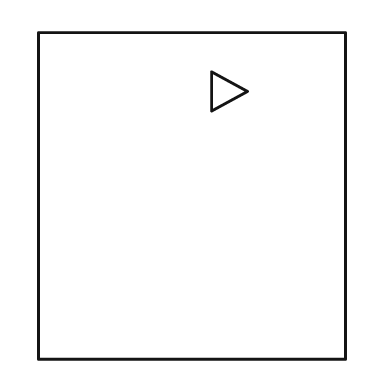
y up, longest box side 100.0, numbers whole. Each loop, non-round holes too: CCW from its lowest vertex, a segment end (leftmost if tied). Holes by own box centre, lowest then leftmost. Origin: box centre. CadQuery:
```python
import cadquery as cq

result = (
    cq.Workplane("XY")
    .moveTo(-47.0, -50.0)
    .lineTo(47.0, -50.0)
    .lineTo(47.0, 50.0)
    .lineTo(-47.0, 50.0)
    .close()
    .moveTo(6.0, 26.0)
    .lineTo(17.0, 32.0)
    .lineTo(6.0, 38.0)
    .close()
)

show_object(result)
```